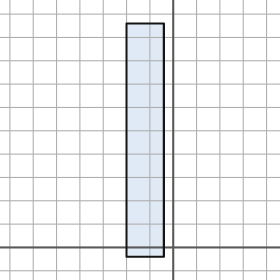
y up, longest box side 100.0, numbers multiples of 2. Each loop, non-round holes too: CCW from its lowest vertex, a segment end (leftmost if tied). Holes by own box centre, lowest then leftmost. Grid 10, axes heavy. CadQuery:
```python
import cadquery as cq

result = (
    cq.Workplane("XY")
    .moveTo(-20.0, -4.0)
    .lineTo(-4.0, -4.0)
    .lineTo(-4.0, 96.0)
    .lineTo(-20.0, 96.0)
    .close()
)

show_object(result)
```